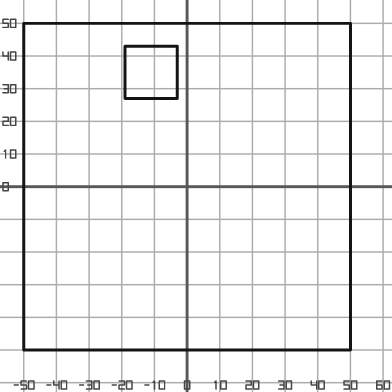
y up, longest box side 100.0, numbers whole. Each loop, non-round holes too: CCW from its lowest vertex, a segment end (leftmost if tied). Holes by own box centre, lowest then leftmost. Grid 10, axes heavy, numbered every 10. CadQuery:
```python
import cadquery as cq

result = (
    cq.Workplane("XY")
    .moveTo(-50.0, -50.0)
    .lineTo(50.0, -50.0)
    .lineTo(50.0, 50.0)
    .lineTo(-50.0, 50.0)
    .close()
    .moveTo(-19.0, 27.0)
    .lineTo(-3.0, 27.0)
    .lineTo(-3.0, 43.0)
    .lineTo(-19.0, 43.0)
    .close()
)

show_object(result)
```